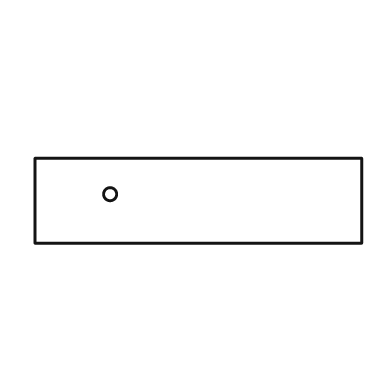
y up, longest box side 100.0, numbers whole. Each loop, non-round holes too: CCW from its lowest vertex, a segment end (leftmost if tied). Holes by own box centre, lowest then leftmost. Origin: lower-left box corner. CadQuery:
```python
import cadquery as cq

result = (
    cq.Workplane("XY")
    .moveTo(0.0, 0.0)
    .lineTo(100.0, 0.0)
    .lineTo(100.0, 26.0)
    .lineTo(0.0, 26.0)
    .close()
    .moveTo(23.0, 15.0)
    .circle(2.0)
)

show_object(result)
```